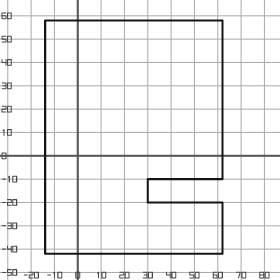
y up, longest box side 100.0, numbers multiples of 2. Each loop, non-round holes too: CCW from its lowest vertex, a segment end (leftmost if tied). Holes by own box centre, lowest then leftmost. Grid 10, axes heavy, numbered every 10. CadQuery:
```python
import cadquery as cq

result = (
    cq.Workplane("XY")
    .moveTo(-14.0, -42.0)
    .lineTo(62.0, -42.0)
    .lineTo(62.0, -20.0)
    .lineTo(30.0, -20.0)
    .lineTo(30.0, -10.0)
    .lineTo(62.0, -10.0)
    .lineTo(62.0, 58.0)
    .lineTo(-14.0, 58.0)
    .close()
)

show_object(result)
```